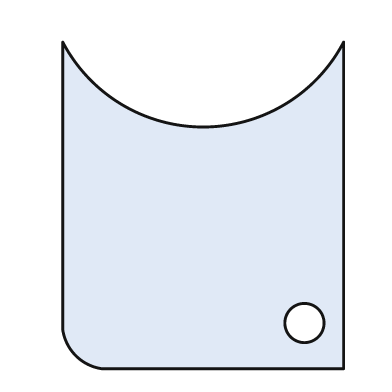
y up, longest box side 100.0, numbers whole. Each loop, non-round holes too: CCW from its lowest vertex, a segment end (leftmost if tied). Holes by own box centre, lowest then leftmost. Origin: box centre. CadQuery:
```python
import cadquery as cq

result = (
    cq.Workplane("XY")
    .moveTo(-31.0, -50.0)
    .lineTo(43.0, -50.0)
    .lineTo(43.0, 50.0)
    .threePointArc((0.0, 24.0), (-43.0, 50.0))
    .lineTo(-43.0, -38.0)
    .threePointArc((-39.0, -46.0), (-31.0, -50.0))
    .close()
    .moveTo(31.0, -36.0)
    .circle(6.0)
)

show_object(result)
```